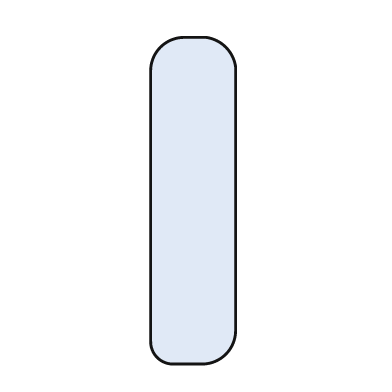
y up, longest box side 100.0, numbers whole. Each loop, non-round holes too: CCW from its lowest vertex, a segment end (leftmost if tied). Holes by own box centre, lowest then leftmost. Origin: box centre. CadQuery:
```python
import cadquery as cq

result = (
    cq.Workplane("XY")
    .moveTo(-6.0, -50.0)
    .lineTo(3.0, -50.0)
    .threePointArc((10.0, -47.0), (13.0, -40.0))
    .lineTo(13.0, 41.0)
    .threePointArc((10.0, 47.0), (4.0, 50.0))
    .lineTo(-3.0, 50.0)
    .threePointArc((-10.0, 47.0), (-13.0, 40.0))
    .lineTo(-13.0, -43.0)
    .threePointArc((-11.0, -48.0), (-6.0, -50.0))
    .close()
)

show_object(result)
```